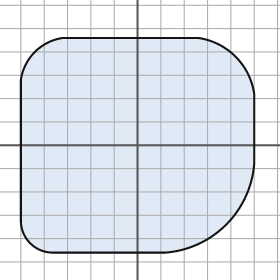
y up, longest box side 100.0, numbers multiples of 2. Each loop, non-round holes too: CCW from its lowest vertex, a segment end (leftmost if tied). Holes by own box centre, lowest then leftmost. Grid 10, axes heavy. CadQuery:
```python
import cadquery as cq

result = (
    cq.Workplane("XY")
    .moveTo(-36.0, -46.0)
    .lineTo(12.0, -46.0)
    .threePointArc((38.0, -34.0), (50.0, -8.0))
    .lineTo(50.0, 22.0)
    .threePointArc((42.0, 38.0), (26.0, 46.0))
    .lineTo(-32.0, 46.0)
    .threePointArc((-44.0, 40.0), (-50.0, 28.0))
    .lineTo(-50.0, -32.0)
    .threePointArc((-46.0, -42.0), (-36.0, -46.0))
    .close()
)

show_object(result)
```